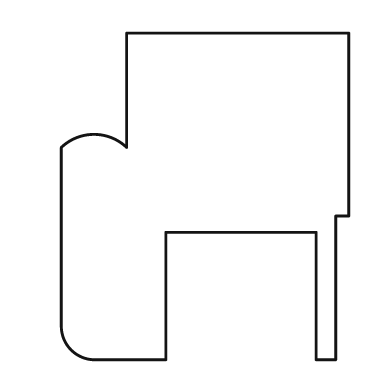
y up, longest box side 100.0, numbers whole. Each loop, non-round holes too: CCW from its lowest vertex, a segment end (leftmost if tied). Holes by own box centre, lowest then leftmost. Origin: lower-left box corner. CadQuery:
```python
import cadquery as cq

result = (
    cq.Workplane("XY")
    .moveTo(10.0, 0.0)
    .lineTo(32.0, 0.0)
    .lineTo(32.0, 39.0)
    .lineTo(78.0, 39.0)
    .lineTo(78.0, 0.0)
    .lineTo(84.0, 0.0)
    .lineTo(84.0, 44.0)
    .lineTo(88.0, 44.0)
    .lineTo(88.0, 100.0)
    .lineTo(20.0, 100.0)
    .lineTo(20.0, 65.0)
    .threePointArc((10.0, 69.0), (0.0, 65.0))
    .lineTo(0.0, 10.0)
    .threePointArc((3.0, 3.0), (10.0, 0.0))
    .close()
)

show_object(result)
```